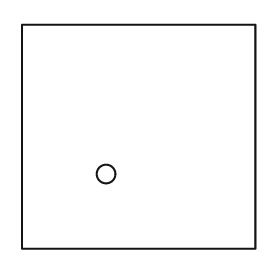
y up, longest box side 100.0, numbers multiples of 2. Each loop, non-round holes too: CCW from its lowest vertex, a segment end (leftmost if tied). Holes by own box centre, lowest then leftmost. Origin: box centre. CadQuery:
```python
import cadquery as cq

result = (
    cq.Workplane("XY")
    .moveTo(-50.0, -48.0)
    .lineTo(50.0, -48.0)
    .lineTo(50.0, 48.0)
    .lineTo(-50.0, 48.0)
    .close()
    .moveTo(-14.0, -16.0)
    .circle(4.0)
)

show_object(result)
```